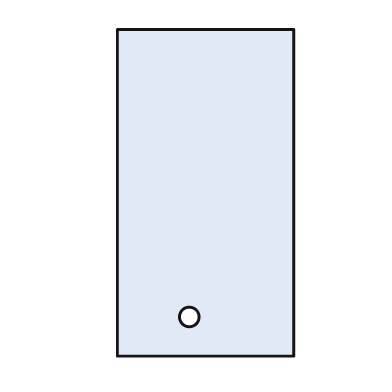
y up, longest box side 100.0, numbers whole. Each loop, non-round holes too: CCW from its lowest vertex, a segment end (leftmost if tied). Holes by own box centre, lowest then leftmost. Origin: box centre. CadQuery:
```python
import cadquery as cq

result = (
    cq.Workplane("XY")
    .moveTo(-27.0, -50.0)
    .lineTo(27.0, -50.0)
    .lineTo(27.0, 50.0)
    .lineTo(-27.0, 50.0)
    .close()
    .moveTo(-5.0, -38.0)
    .circle(3.0)
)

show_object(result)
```